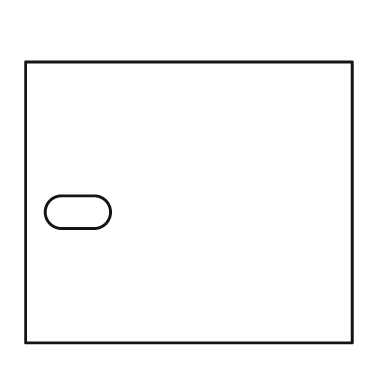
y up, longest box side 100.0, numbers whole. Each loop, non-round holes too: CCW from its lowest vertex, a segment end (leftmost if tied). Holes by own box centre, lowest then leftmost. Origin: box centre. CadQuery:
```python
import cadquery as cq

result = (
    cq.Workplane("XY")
    .moveTo(-50.0, -43.0)
    .lineTo(50.0, -43.0)
    .lineTo(50.0, 43.0)
    .lineTo(-50.0, 43.0)
    .close()
    .moveTo(-39.0, -8.0)
    .lineTo(-29.0, -8.0)
    .threePointArc((-24.0, -3.0), (-29.0, 2.0))
    .lineTo(-39.0, 2.0)
    .threePointArc((-44.0, -3.0), (-39.0, -8.0))
    .close()
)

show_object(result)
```